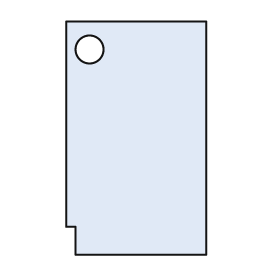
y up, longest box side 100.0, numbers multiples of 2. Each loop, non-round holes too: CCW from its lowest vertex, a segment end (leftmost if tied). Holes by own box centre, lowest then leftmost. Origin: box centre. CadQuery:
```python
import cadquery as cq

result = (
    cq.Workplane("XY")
    .moveTo(-26.0, -50.0)
    .lineTo(30.0, -50.0)
    .lineTo(30.0, 50.0)
    .lineTo(-30.0, 50.0)
    .lineTo(-30.0, -38.0)
    .lineTo(-26.0, -38.0)
    .close()
    .moveTo(-20.0, 38.0)
    .circle(6.0)
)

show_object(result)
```